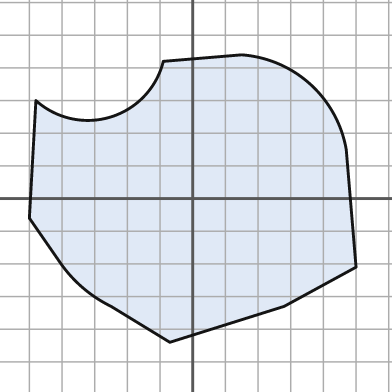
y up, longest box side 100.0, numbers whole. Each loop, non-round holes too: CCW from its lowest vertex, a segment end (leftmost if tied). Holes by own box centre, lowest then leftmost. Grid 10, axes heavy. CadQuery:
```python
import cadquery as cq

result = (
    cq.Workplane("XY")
    .moveTo(-7.0, -44.0)
    .lineTo(28.0, -33.0)
    .lineTo(50.0, -21.0)
    .lineTo(47.0, 15.0)
    .threePointArc((36.0, 35.0), (15.0, 44.0))
    .lineTo(-9.0, 42.0)
    .threePointArc((-25.0, 25.0), (-48.0, 30.0))
    .lineTo(-50.0, -6.0)
    .lineTo(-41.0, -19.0)
    .threePointArc((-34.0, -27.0), (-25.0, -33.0))
    .close()
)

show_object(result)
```